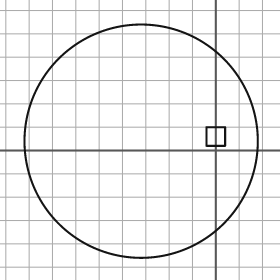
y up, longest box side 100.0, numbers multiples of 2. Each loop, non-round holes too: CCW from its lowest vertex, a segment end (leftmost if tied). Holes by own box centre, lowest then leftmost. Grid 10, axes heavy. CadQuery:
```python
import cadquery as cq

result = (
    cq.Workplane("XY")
    .moveTo(-32.0, 4.0)
    .circle(50.0)
    .moveTo(-4.0, 2.0)
    .lineTo(4.0, 2.0)
    .lineTo(4.0, 10.0)
    .lineTo(-4.0, 10.0)
    .close()
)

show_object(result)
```